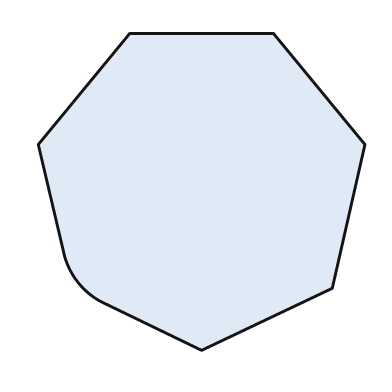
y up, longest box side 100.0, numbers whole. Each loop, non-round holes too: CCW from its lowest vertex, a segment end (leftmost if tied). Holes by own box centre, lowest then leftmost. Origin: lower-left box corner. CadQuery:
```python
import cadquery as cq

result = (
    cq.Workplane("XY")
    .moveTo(50.0, 0.0)
    .lineTo(90.0, 19.0)
    .lineTo(100.0, 63.0)
    .lineTo(72.0, 97.0)
    .lineTo(28.0, 97.0)
    .lineTo(0.0, 63.0)
    .lineTo(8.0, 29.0)
    .threePointArc((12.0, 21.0), (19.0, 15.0))
    .close()
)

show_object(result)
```